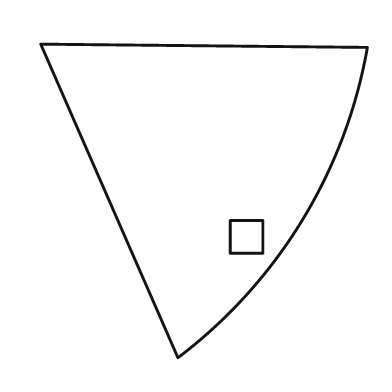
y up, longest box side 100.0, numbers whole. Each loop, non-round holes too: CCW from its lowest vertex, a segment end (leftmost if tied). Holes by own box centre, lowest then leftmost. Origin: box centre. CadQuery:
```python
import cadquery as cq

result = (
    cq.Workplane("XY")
    .moveTo(-8.0, -48.0)
    .threePointArc((30.0, -6.0), (50.0, 47.0))
    .lineTo(-50.0, 48.0)
    .close()
    .moveTo(8.0, -16.0)
    .lineTo(18.0, -16.0)
    .lineTo(18.0, -6.0)
    .lineTo(8.0, -6.0)
    .close()
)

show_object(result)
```